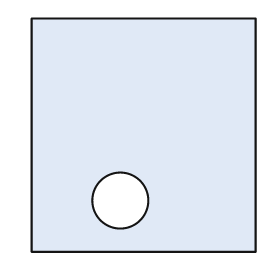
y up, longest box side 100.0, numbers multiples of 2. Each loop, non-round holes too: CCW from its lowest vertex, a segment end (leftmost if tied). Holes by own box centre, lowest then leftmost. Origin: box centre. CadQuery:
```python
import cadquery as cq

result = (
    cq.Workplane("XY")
    .moveTo(-48.0, -50.0)
    .lineTo(48.0, -50.0)
    .lineTo(48.0, 50.0)
    .lineTo(-48.0, 50.0)
    .close()
    .moveTo(-10.0, -28.0)
    .circle(12.0)
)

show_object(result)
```